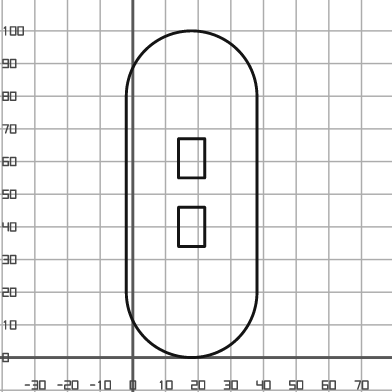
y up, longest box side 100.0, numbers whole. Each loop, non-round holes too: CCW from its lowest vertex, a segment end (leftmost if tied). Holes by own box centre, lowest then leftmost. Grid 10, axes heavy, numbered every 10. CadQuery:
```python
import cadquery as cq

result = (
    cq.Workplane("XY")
    .moveTo(-2.0, 20.0)
    .threePointArc((18.0, 0.0), (38.0, 20.0))
    .lineTo(38.0, 80.0)
    .threePointArc((18.0, 100.0), (-2.0, 80.0))
    .close()
    .moveTo(14.0, 34.0)
    .lineTo(22.0, 34.0)
    .lineTo(22.0, 46.0)
    .lineTo(14.0, 46.0)
    .close()
    .moveTo(14.0, 55.0)
    .lineTo(22.0, 55.0)
    .lineTo(22.0, 67.0)
    .lineTo(14.0, 67.0)
    .close()
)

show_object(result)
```